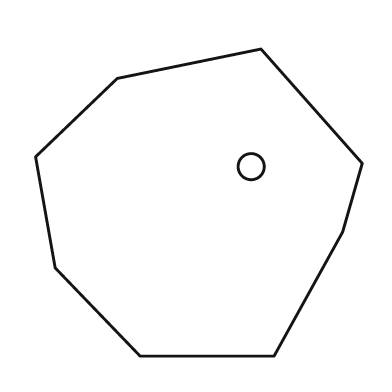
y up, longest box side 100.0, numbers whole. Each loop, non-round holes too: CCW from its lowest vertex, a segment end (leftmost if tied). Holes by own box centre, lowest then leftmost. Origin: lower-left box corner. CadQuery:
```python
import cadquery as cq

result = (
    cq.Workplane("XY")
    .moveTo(32.0, 0.0)
    .lineTo(73.0, 0.0)
    .lineTo(94.0, 38.0)
    .lineTo(100.0, 59.0)
    .lineTo(69.0, 94.0)
    .lineTo(25.0, 85.0)
    .lineTo(0.0, 61.0)
    .lineTo(6.0, 27.0)
    .close()
    .moveTo(66.0, 58.0)
    .circle(4.0)
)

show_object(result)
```